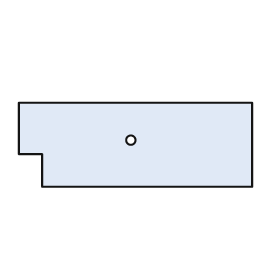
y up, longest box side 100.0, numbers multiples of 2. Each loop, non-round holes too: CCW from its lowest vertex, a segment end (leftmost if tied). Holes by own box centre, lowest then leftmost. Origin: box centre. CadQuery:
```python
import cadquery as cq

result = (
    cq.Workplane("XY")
    .moveTo(-40.0, -18.0)
    .lineTo(50.0, -18.0)
    .lineTo(50.0, 18.0)
    .lineTo(-50.0, 18.0)
    .lineTo(-50.0, -4.0)
    .lineTo(-40.0, -4.0)
    .close()
    .moveTo(-2.0, 2.0)
    .circle(2.0)
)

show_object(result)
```